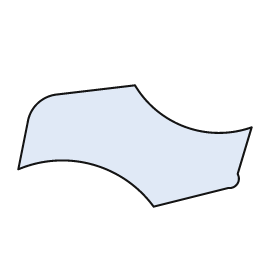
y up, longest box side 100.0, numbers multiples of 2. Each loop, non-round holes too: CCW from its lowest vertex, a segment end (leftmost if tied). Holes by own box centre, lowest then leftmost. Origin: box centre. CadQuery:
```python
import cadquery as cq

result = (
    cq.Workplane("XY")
    .moveTo(8.0, -26.0)
    .lineTo(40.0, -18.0)
    .threePointArc((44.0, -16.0), (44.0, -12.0))
    .lineTo(50.0, 8.0)
    .threePointArc((22.0, 8.0), (0.0, 26.0))
    .lineTo(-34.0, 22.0)
    .threePointArc((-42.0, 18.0), (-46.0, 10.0))
    .lineTo(-50.0, -10.0)
    .threePointArc((-18.0, -8.0), (8.0, -26.0))
    .close()
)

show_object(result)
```